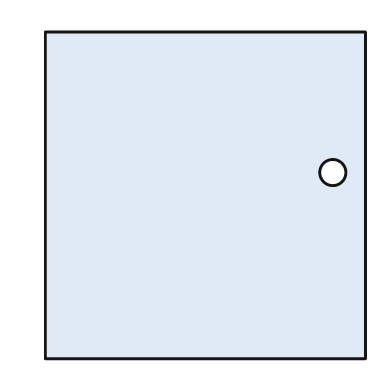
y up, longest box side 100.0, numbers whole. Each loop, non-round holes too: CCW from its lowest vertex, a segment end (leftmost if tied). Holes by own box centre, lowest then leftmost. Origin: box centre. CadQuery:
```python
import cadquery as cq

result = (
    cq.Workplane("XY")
    .moveTo(-49.0, -50.0)
    .lineTo(49.0, -50.0)
    .lineTo(49.0, 50.0)
    .lineTo(-49.0, 50.0)
    .close()
    .moveTo(39.0, 7.0)
    .circle(4.0)
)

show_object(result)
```